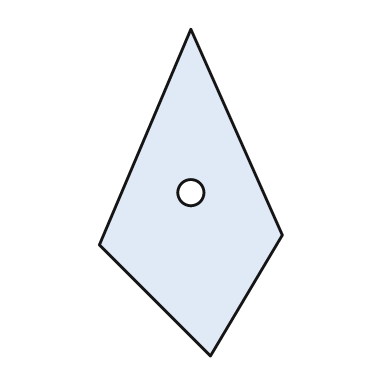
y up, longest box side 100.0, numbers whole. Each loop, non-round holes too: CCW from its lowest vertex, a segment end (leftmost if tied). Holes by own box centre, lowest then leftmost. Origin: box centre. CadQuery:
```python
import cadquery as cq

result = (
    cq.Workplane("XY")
    .moveTo(6.0, -50.0)
    .lineTo(28.0, -13.0)
    .lineTo(0.0, 50.0)
    .lineTo(-28.0, -16.0)
    .close()
    .moveTo(0.0, 0.0)
    .circle(4.0)
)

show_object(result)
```